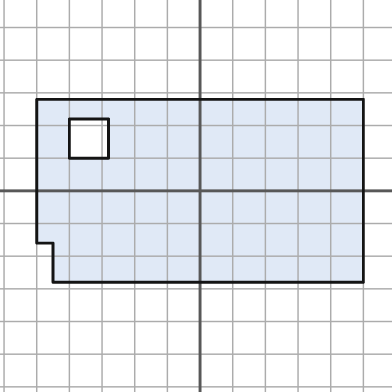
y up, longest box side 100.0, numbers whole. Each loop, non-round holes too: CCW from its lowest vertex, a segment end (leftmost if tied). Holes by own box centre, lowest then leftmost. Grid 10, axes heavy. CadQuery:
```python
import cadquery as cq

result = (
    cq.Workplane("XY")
    .moveTo(-45.0, -28.0)
    .lineTo(50.0, -28.0)
    .lineTo(50.0, 28.0)
    .lineTo(-50.0, 28.0)
    .lineTo(-50.0, -16.0)
    .lineTo(-45.0, -16.0)
    .close()
    .moveTo(-40.0, 10.0)
    .lineTo(-28.0, 10.0)
    .lineTo(-28.0, 22.0)
    .lineTo(-40.0, 22.0)
    .close()
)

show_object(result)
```